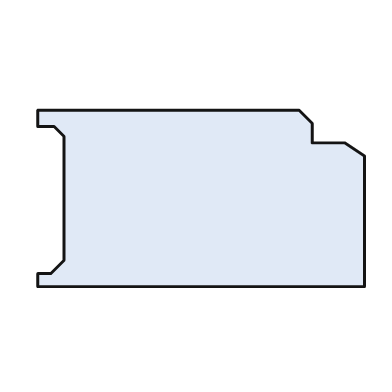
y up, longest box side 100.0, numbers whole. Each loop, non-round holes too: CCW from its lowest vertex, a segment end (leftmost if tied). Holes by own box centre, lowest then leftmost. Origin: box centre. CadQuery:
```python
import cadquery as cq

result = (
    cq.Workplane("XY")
    .moveTo(-50.0, -27.0)
    .lineTo(50.0, -27.0)
    .lineTo(50.0, 13.0)
    .lineTo(44.0, 17.0)
    .lineTo(34.0, 17.0)
    .lineTo(34.0, 23.0)
    .lineTo(30.0, 27.0)
    .lineTo(-50.0, 27.0)
    .lineTo(-50.0, 22.0)
    .lineTo(-45.0, 22.0)
    .lineTo(-42.0, 19.0)
    .lineTo(-42.0, -19.0)
    .lineTo(-46.0, -23.0)
    .lineTo(-50.0, -23.0)
    .close()
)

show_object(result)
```